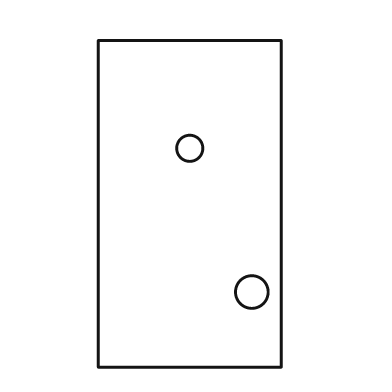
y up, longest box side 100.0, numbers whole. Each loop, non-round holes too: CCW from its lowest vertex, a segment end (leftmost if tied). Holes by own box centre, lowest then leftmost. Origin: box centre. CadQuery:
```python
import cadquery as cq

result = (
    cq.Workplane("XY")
    .moveTo(-28.0, -50.0)
    .lineTo(28.0, -50.0)
    .lineTo(28.0, 50.0)
    .lineTo(-28.0, 50.0)
    .close()
    .moveTo(19.0, -27.0)
    .circle(5.0)
    .moveTo(0.0, 17.0)
    .circle(4.0)
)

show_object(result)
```